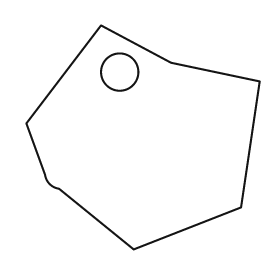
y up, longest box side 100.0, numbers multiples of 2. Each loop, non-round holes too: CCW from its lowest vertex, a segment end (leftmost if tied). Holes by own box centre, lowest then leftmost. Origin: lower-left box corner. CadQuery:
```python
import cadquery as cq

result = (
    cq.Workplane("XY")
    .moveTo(46.0, 0.0)
    .lineTo(92.0, 18.0)
    .lineTo(100.0, 72.0)
    .lineTo(62.0, 80.0)
    .lineTo(32.0, 96.0)
    .lineTo(0.0, 54.0)
    .lineTo(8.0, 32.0)
    .threePointArc((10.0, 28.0), (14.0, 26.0))
    .close()
    .moveTo(40.0, 76.0)
    .circle(8.0)
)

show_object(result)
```